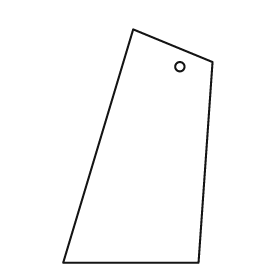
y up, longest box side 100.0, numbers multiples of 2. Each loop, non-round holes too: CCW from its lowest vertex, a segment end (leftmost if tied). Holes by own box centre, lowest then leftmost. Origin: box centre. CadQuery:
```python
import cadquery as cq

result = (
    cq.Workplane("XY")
    .moveTo(-32.0, -50.0)
    .lineTo(26.0, -50.0)
    .lineTo(32.0, 36.0)
    .lineTo(-2.0, 50.0)
    .close()
    .moveTo(18.0, 34.0)
    .circle(2.0)
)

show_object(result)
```